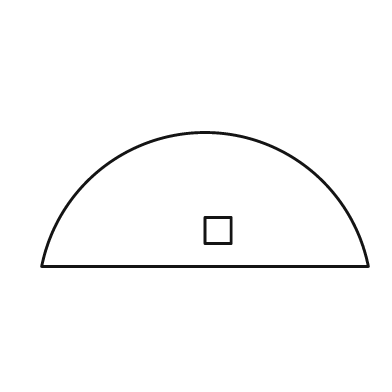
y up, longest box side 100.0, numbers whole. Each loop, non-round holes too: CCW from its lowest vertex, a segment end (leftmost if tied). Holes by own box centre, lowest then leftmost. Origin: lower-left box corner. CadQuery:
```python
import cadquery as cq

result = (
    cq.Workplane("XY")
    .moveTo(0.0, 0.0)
    .lineTo(100.0, 0.0)
    .threePointArc((50.0, 41.0), (0.0, 0.0))
    .close()
    .moveTo(50.0, 7.0)
    .lineTo(58.0, 7.0)
    .lineTo(58.0, 15.0)
    .lineTo(50.0, 15.0)
    .close()
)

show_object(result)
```